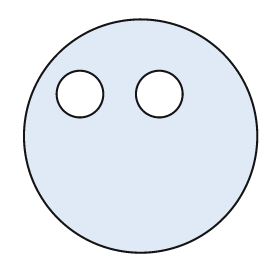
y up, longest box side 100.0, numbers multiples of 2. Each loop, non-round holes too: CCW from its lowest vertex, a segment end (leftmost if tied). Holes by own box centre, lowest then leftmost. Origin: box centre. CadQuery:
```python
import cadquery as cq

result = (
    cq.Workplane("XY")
    .moveTo(0.0, 0.0)
    .circle(50.0)
    .moveTo(-26.0, 18.0)
    .circle(10.0)
    .moveTo(8.0, 18.0)
    .circle(10.0)
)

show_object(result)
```